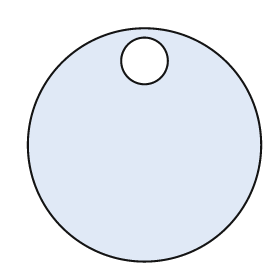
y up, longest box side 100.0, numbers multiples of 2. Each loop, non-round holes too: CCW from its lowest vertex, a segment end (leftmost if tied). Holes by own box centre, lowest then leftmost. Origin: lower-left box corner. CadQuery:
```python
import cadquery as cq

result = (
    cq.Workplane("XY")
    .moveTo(50.0, 50.0)
    .circle(50.0)
    .moveTo(50.0, 86.0)
    .circle(10.0)
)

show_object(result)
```